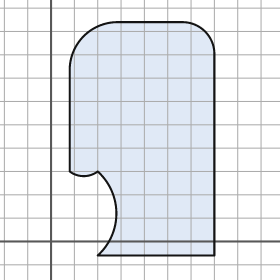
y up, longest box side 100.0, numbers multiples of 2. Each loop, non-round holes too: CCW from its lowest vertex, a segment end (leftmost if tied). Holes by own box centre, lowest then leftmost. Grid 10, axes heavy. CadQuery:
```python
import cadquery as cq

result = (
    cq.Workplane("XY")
    .moveTo(20.0, -6.0)
    .lineTo(70.0, -6.0)
    .lineTo(70.0, 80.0)
    .threePointArc((66.0, 90.0), (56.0, 94.0))
    .lineTo(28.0, 94.0)
    .threePointArc((14.0, 88.0), (8.0, 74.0))
    .lineTo(8.0, 30.0)
    .threePointArc((14.0, 28.0), (20.0, 30.0))
    .threePointArc((28.0, 12.0), (20.0, -6.0))
    .close()
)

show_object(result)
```